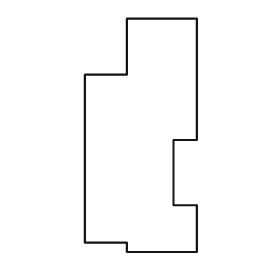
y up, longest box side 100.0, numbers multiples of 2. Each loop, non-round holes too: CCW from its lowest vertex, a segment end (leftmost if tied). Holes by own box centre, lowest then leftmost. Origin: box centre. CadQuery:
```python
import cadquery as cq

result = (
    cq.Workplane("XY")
    .moveTo(-6.0, -50.0)
    .lineTo(24.0, -50.0)
    .lineTo(24.0, -30.0)
    .lineTo(14.0, -30.0)
    .lineTo(14.0, -2.0)
    .lineTo(24.0, -2.0)
    .lineTo(24.0, 50.0)
    .lineTo(-6.0, 50.0)
    .lineTo(-6.0, 26.0)
    .lineTo(-24.0, 26.0)
    .lineTo(-24.0, -46.0)
    .lineTo(-6.0, -46.0)
    .close()
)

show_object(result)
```